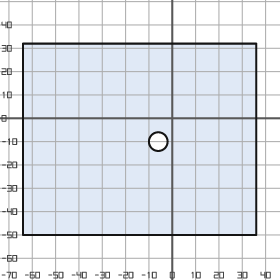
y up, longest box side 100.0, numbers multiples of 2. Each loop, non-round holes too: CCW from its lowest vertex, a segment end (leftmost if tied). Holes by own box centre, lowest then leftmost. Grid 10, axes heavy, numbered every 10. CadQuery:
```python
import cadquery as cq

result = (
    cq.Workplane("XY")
    .moveTo(-64.0, -50.0)
    .lineTo(36.0, -50.0)
    .lineTo(36.0, 32.0)
    .lineTo(-64.0, 32.0)
    .close()
    .moveTo(-6.0, -10.0)
    .circle(4.0)
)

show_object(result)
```